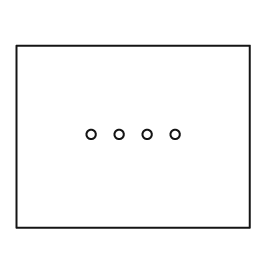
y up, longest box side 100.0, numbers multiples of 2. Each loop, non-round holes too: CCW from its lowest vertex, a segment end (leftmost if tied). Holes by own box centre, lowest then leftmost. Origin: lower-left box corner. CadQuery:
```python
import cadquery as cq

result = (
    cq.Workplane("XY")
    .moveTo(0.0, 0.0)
    .lineTo(100.0, 0.0)
    .lineTo(100.0, 78.0)
    .lineTo(0.0, 78.0)
    .close()
    .moveTo(32.0, 40.0)
    .circle(2.0)
    .moveTo(44.0, 40.0)
    .circle(2.0)
    .moveTo(56.0, 40.0)
    .circle(2.0)
    .moveTo(68.0, 40.0)
    .circle(2.0)
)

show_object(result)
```